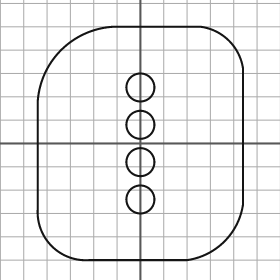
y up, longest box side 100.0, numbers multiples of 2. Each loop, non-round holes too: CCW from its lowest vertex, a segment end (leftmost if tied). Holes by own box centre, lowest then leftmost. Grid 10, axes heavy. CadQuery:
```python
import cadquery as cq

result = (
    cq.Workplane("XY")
    .moveTo(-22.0, -50.0)
    .lineTo(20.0, -50.0)
    .threePointArc((36.0, -42.0), (44.0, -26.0))
    .lineTo(44.0, 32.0)
    .threePointArc((38.0, 44.0), (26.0, 50.0))
    .lineTo(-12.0, 50.0)
    .threePointArc((-34.0, 40.0), (-44.0, 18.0))
    .lineTo(-44.0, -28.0)
    .threePointArc((-38.0, -44.0), (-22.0, -50.0))
    .close()
    .moveTo(0.0, -24.0)
    .circle(6.0)
    .moveTo(0.0, -8.0)
    .circle(6.0)
    .moveTo(0.0, 8.0)
    .circle(6.0)
    .moveTo(0.0, 24.0)
    .circle(6.0)
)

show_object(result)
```